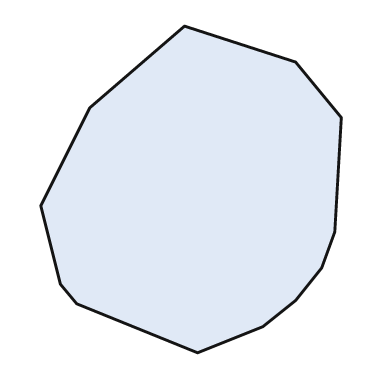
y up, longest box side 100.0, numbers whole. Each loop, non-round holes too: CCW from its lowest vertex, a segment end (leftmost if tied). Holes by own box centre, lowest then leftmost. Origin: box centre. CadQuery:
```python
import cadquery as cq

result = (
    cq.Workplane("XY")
    .moveTo(2.0, -50.0)
    .lineTo(22.0, -42.0)
    .lineTo(32.0, -34.0)
    .lineTo(40.0, -24.0)
    .lineTo(44.0, -13.0)
    .lineTo(46.0, 22.0)
    .lineTo(32.0, 39.0)
    .lineTo(-2.0, 50.0)
    .lineTo(-31.0, 25.0)
    .lineTo(-46.0, -5.0)
    .lineTo(-40.0, -29.0)
    .lineTo(-35.0, -35.0)
    .close()
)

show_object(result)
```